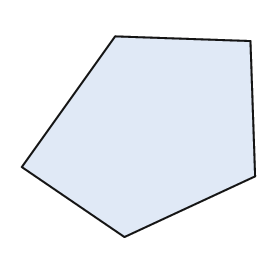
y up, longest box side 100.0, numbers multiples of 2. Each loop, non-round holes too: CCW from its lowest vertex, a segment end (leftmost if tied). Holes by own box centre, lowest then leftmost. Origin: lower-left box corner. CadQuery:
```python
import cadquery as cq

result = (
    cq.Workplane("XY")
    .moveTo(44.0, 0.0)
    .lineTo(100.0, 26.0)
    .lineTo(98.0, 84.0)
    .lineTo(40.0, 86.0)
    .lineTo(0.0, 30.0)
    .close()
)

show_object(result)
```